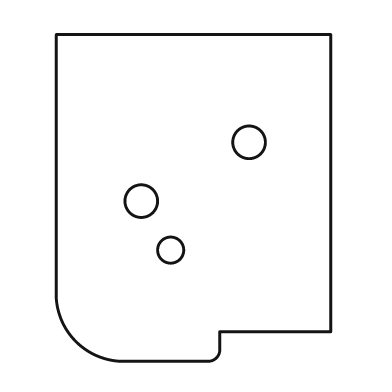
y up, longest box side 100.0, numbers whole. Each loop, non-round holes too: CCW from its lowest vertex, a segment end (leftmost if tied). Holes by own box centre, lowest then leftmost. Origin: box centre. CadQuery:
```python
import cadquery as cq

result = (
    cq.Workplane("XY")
    .moveTo(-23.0, -50.0)
    .lineTo(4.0, -50.0)
    .threePointArc((7.0, -49.0), (8.0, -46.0))
    .lineTo(8.0, -41.0)
    .lineTo(42.0, -41.0)
    .lineTo(42.0, 50.0)
    .lineTo(-42.0, 50.0)
    .lineTo(-42.0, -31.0)
    .threePointArc((-36.0, -44.0), (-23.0, -50.0))
    .close()
    .moveTo(-7.0, -16.0)
    .circle(4.0)
    .moveTo(-16.0, -1.0)
    .circle(5.0)
    .moveTo(17.0, 17.0)
    .circle(5.0)
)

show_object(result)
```